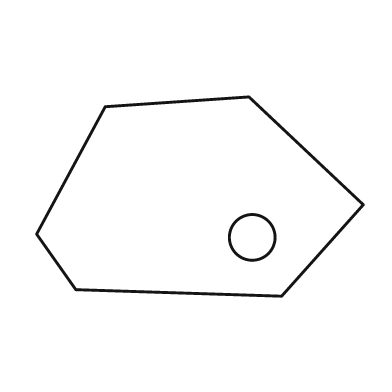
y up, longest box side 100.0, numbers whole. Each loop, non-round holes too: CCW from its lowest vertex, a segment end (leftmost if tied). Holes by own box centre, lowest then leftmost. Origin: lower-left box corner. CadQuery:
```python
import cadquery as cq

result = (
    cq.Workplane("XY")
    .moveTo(75.0, 0.0)
    .lineTo(100.0, 28.0)
    .lineTo(65.0, 61.0)
    .lineTo(21.0, 58.0)
    .lineTo(0.0, 19.0)
    .lineTo(12.0, 2.0)
    .close()
    .moveTo(66.0, 18.0)
    .circle(7.0)
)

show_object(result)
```